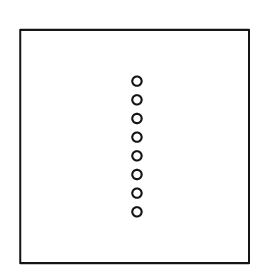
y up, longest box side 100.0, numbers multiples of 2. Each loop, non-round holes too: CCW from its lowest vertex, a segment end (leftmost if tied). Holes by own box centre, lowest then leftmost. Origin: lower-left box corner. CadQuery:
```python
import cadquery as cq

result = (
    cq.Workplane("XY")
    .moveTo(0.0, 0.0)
    .lineTo(98.0, 0.0)
    .lineTo(98.0, 100.0)
    .lineTo(0.0, 100.0)
    .close()
    .moveTo(50.0, 22.0)
    .circle(2.0)
    .moveTo(50.0, 30.0)
    .circle(2.0)
    .moveTo(50.0, 38.0)
    .circle(2.0)
    .moveTo(50.0, 46.0)
    .circle(2.0)
    .moveTo(50.0, 54.0)
    .circle(2.0)
    .moveTo(50.0, 62.0)
    .circle(2.0)
    .moveTo(50.0, 70.0)
    .circle(2.0)
    .moveTo(50.0, 78.0)
    .circle(2.0)
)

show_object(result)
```